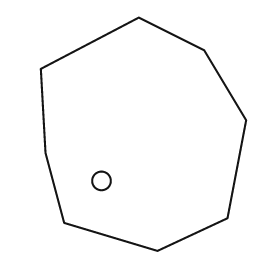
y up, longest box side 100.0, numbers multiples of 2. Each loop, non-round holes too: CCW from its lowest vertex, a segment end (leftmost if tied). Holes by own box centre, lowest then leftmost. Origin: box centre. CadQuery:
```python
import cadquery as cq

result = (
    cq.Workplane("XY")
    .moveTo(6.0, -50.0)
    .lineTo(36.0, -36.0)
    .lineTo(44.0, 6.0)
    .lineTo(26.0, 36.0)
    .lineTo(-2.0, 50.0)
    .lineTo(-44.0, 28.0)
    .lineTo(-42.0, -8.0)
    .lineTo(-34.0, -38.0)
    .close()
    .moveTo(-18.0, -20.0)
    .circle(4.0)
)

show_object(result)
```